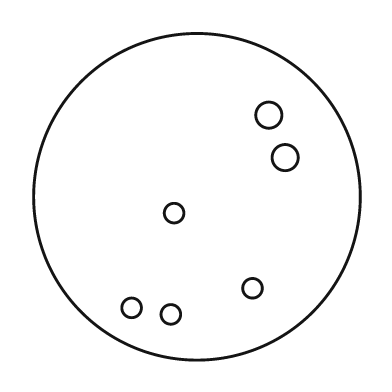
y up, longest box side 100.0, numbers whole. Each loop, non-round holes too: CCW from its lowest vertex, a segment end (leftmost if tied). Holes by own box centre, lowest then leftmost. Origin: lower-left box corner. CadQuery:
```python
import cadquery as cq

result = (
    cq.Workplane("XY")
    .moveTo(50.0, 50.0)
    .circle(50.0)
    .moveTo(42.0, 14.0)
    .circle(3.0)
    .moveTo(30.0, 16.0)
    .circle(3.0)
    .moveTo(67.0, 22.0)
    .circle(3.0)
    .moveTo(43.0, 45.0)
    .circle(3.0)
    .moveTo(77.0, 62.0)
    .circle(4.0)
    .moveTo(72.0, 75.0)
    .circle(4.0)
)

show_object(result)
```